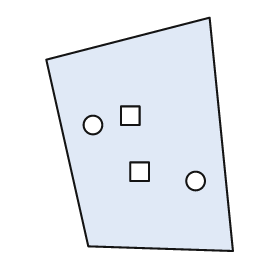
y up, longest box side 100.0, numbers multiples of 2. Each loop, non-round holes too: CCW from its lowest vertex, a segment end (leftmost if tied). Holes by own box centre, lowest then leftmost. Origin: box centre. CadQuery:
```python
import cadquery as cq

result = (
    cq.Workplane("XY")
    .moveTo(40.0, -50.0)
    .lineTo(30.0, 50.0)
    .lineTo(-40.0, 32.0)
    .lineTo(-22.0, -48.0)
    .close()
    .moveTo(24.0, -20.0)
    .circle(4.0)
    .moveTo(-4.0, -20.0)
    .lineTo(4.0, -20.0)
    .lineTo(4.0, -12.0)
    .lineTo(-4.0, -12.0)
    .close()
    .moveTo(-20.0, 4.0)
    .circle(4.0)
    .moveTo(-8.0, 4.0)
    .lineTo(0.0, 4.0)
    .lineTo(0.0, 12.0)
    .lineTo(-8.0, 12.0)
    .close()
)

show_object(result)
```